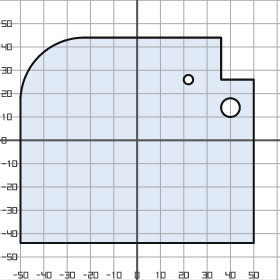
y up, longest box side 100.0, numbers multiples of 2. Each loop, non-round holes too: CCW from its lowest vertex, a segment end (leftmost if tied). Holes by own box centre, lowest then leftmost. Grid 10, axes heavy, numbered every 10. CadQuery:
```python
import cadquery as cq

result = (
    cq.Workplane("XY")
    .moveTo(-50.0, -44.0)
    .lineTo(50.0, -44.0)
    .lineTo(50.0, 26.0)
    .lineTo(36.0, 26.0)
    .lineTo(36.0, 44.0)
    .lineTo(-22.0, 44.0)
    .threePointArc((-42.0, 36.0), (-50.0, 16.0))
    .close()
    .moveTo(40.0, 14.0)
    .circle(4.0)
    .moveTo(22.0, 26.0)
    .circle(2.0)
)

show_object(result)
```